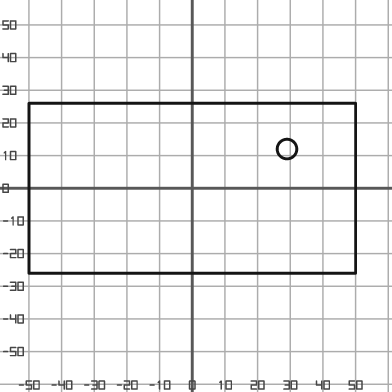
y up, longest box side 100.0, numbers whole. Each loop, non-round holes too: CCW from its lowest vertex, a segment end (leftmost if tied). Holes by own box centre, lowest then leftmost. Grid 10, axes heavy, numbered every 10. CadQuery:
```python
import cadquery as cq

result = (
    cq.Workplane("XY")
    .moveTo(-50.0, -26.0)
    .lineTo(50.0, -26.0)
    .lineTo(50.0, 26.0)
    .lineTo(-50.0, 26.0)
    .close()
    .moveTo(29.0, 12.0)
    .circle(3.0)
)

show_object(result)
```